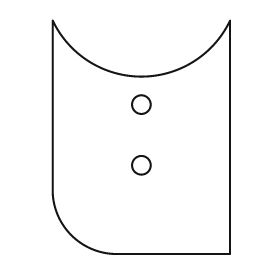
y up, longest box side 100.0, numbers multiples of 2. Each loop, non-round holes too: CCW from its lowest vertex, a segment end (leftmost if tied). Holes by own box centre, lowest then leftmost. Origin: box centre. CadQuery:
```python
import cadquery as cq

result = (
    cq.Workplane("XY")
    .moveTo(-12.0, -50.0)
    .lineTo(38.0, -50.0)
    .lineTo(38.0, 50.0)
    .threePointArc((0.0, 26.0), (-38.0, 50.0))
    .lineTo(-38.0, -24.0)
    .threePointArc((-30.0, -42.0), (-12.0, -50.0))
    .close()
    .moveTo(0.0, -12.0)
    .circle(4.0)
    .moveTo(0.0, 14.0)
    .circle(4.0)
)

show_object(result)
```